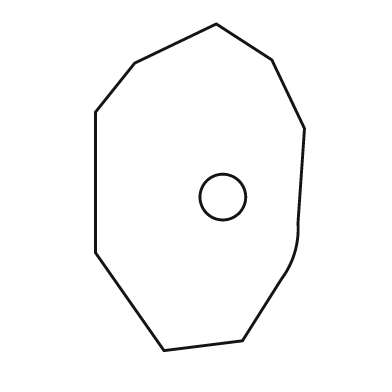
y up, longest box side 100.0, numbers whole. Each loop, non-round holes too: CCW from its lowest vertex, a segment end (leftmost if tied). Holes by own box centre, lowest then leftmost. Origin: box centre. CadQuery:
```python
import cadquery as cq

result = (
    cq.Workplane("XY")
    .moveTo(-11.0, -50.0)
    .lineTo(13.0, -47.0)
    .lineTo(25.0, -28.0)
    .threePointArc((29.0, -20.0), (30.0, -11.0))
    .lineTo(32.0, 18.0)
    .lineTo(22.0, 39.0)
    .lineTo(5.0, 50.0)
    .lineTo(-20.0, 38.0)
    .lineTo(-32.0, 23.0)
    .lineTo(-32.0, -20.0)
    .close()
    .moveTo(7.0, -3.0)
    .circle(7.0)
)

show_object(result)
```